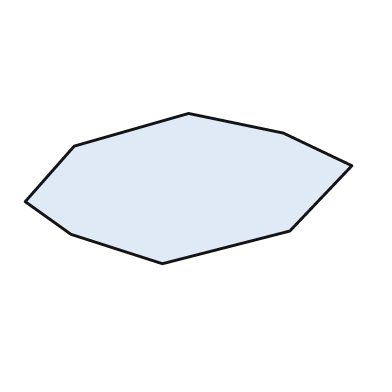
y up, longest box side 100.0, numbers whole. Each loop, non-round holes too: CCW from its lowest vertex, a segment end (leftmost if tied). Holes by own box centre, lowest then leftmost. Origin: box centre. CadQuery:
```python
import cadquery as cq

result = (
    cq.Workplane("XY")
    .moveTo(-8.0, -23.0)
    .lineTo(31.0, -13.0)
    .lineTo(50.0, 7.0)
    .lineTo(29.0, 17.0)
    .lineTo(0.0, 23.0)
    .lineTo(-35.0, 13.0)
    .lineTo(-50.0, -4.0)
    .lineTo(-36.0, -14.0)
    .close()
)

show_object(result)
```